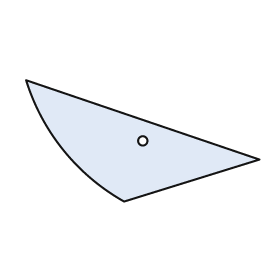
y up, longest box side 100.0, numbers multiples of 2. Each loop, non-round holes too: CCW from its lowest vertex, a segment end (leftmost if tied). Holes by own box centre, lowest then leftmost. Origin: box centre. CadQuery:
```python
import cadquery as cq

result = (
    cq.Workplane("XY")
    .moveTo(-8.0, -26.0)
    .lineTo(50.0, -8.0)
    .lineTo(-50.0, 26.0)
    .threePointArc((-34.0, -4.0), (-8.0, -26.0))
    .close()
    .moveTo(0.0, 0.0)
    .circle(2.0)
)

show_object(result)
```